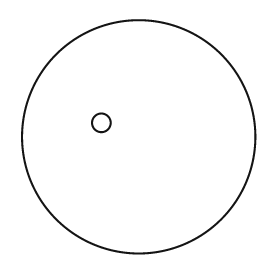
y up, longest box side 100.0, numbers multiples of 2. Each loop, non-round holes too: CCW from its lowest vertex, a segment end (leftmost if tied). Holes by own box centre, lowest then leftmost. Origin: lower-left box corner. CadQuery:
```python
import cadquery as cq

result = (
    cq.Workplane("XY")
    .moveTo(50.0, 50.0)
    .circle(50.0)
    .moveTo(34.0, 56.0)
    .circle(4.0)
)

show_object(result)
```